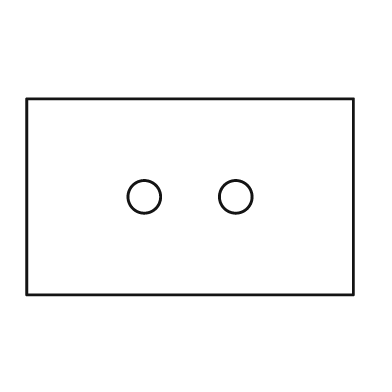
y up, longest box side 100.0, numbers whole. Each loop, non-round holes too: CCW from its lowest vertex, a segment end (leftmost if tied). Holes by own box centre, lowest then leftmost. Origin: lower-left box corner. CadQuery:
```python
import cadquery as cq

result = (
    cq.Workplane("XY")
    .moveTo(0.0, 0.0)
    .lineTo(100.0, 0.0)
    .lineTo(100.0, 60.0)
    .lineTo(0.0, 60.0)
    .close()
    .moveTo(36.0, 30.0)
    .circle(5.0)
    .moveTo(64.0, 30.0)
    .circle(5.0)
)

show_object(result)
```